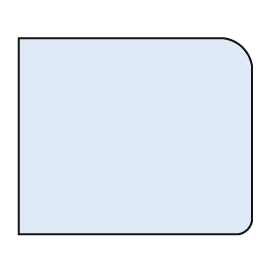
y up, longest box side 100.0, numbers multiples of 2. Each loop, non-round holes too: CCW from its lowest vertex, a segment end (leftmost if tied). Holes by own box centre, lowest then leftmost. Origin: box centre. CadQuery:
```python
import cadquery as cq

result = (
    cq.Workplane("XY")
    .moveTo(-50.0, -42.0)
    .lineTo(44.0, -42.0)
    .threePointArc((48.0, -40.0), (50.0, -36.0))
    .lineTo(50.0, 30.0)
    .threePointArc((46.0, 38.0), (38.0, 42.0))
    .lineTo(-50.0, 42.0)
    .close()
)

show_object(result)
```